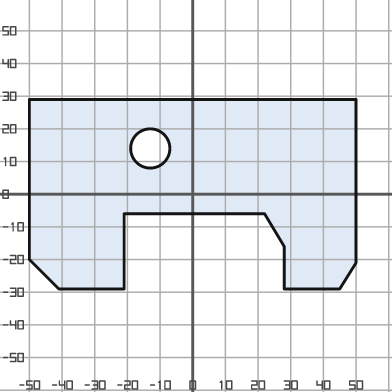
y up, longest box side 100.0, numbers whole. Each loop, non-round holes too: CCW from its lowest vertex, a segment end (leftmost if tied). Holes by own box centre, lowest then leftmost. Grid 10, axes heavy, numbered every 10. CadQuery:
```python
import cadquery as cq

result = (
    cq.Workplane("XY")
    .moveTo(-41.0, -29.0)
    .lineTo(-21.0, -29.0)
    .lineTo(-21.0, -6.0)
    .lineTo(22.0, -6.0)
    .lineTo(28.0, -16.0)
    .lineTo(28.0, -29.0)
    .lineTo(45.0, -29.0)
    .lineTo(50.0, -21.0)
    .lineTo(50.0, 29.0)
    .lineTo(-50.0, 29.0)
    .lineTo(-50.0, -20.0)
    .close()
    .moveTo(-13.0, 14.0)
    .circle(6.0)
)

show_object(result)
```